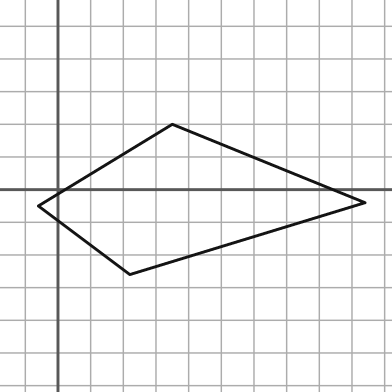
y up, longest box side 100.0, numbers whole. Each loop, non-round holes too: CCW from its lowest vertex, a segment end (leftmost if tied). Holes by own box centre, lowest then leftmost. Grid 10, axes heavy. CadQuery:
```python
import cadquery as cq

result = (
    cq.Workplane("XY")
    .moveTo(22.0, -26.0)
    .lineTo(94.0, -4.0)
    .lineTo(35.0, 20.0)
    .lineTo(-6.0, -5.0)
    .close()
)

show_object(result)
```